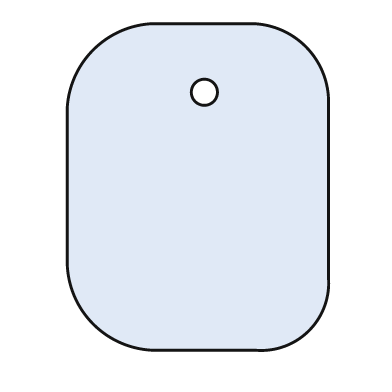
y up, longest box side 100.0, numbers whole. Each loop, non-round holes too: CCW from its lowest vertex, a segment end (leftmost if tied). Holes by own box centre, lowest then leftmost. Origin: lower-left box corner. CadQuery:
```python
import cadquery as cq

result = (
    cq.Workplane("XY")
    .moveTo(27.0, 0.0)
    .lineTo(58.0, 0.0)
    .threePointArc((74.0, 6.0), (80.0, 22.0))
    .lineTo(80.0, 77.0)
    .threePointArc((73.0, 93.0), (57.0, 100.0))
    .lineTo(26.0, 100.0)
    .threePointArc((8.0, 92.0), (0.0, 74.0))
    .lineTo(0.0, 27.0)
    .threePointArc((8.0, 8.0), (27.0, 0.0))
    .close()
    .moveTo(42.0, 79.0)
    .circle(4.0)
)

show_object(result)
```